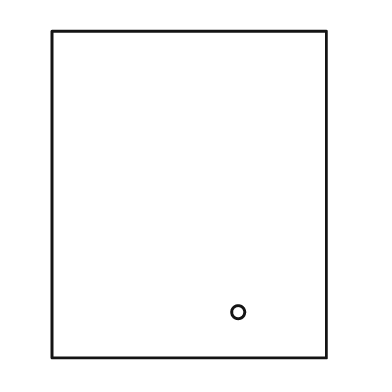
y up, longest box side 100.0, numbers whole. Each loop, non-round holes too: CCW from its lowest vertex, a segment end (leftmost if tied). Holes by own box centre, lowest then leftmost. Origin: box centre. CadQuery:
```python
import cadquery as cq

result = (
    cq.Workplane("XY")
    .moveTo(-42.0, -50.0)
    .lineTo(42.0, -50.0)
    .lineTo(42.0, 50.0)
    .lineTo(-42.0, 50.0)
    .close()
    .moveTo(15.0, -36.0)
    .circle(2.0)
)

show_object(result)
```